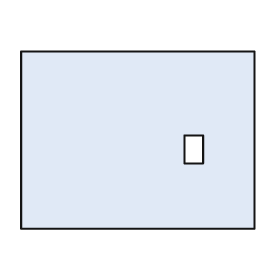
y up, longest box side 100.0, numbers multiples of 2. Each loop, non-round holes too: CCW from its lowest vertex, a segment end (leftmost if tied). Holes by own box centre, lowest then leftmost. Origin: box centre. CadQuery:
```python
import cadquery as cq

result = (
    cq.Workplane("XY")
    .moveTo(-50.0, -38.0)
    .lineTo(50.0, -38.0)
    .lineTo(50.0, 38.0)
    .lineTo(-50.0, 38.0)
    .close()
    .moveTo(20.0, -10.0)
    .lineTo(28.0, -10.0)
    .lineTo(28.0, 2.0)
    .lineTo(20.0, 2.0)
    .close()
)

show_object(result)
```